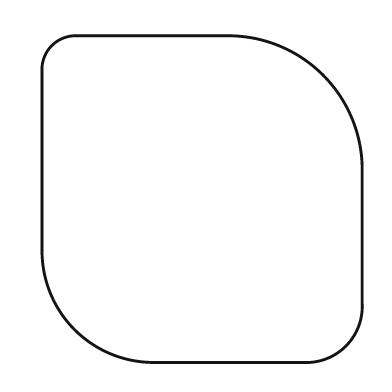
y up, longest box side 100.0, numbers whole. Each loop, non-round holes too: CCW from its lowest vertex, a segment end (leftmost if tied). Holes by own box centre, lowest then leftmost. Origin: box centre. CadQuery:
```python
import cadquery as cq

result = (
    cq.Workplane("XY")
    .moveTo(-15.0, -50.0)
    .lineTo(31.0, -50.0)
    .threePointArc((44.0, -45.0), (49.0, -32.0))
    .lineTo(49.0, 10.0)
    .threePointArc((37.0, 38.0), (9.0, 50.0))
    .lineTo(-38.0, 50.0)
    .threePointArc((-46.0, 47.0), (-49.0, 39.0))
    .lineTo(-49.0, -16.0)
    .threePointArc((-39.0, -40.0), (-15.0, -50.0))
    .close()
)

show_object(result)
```